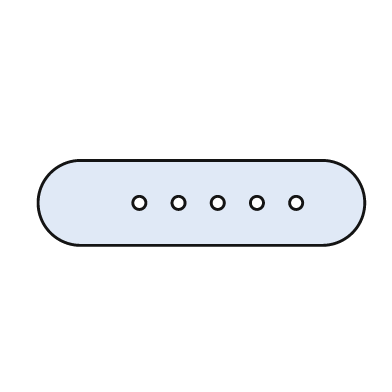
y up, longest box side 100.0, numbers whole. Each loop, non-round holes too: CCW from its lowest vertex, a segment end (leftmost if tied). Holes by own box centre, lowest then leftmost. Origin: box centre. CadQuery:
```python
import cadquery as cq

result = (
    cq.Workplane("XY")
    .moveTo(-37.0, -13.0)
    .lineTo(37.0, -13.0)
    .threePointArc((50.0, 0.0), (37.0, 13.0))
    .lineTo(-37.0, 13.0)
    .threePointArc((-50.0, 0.0), (-37.0, -13.0))
    .close()
    .moveTo(-19.0, 0.0)
    .circle(2.0)
    .moveTo(-7.0, 0.0)
    .circle(2.0)
    .moveTo(5.0, 0.0)
    .circle(2.0)
    .moveTo(17.0, 0.0)
    .circle(2.0)
    .moveTo(29.0, 0.0)
    .circle(2.0)
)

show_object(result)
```